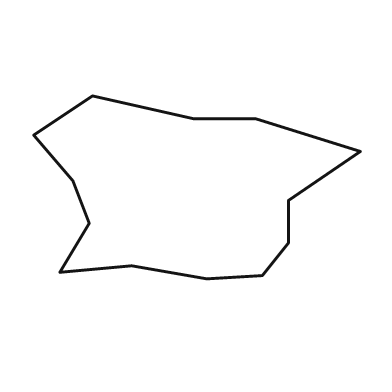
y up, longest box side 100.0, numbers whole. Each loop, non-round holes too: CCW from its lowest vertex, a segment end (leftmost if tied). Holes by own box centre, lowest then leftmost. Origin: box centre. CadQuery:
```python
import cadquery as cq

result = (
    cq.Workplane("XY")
    .moveTo(3.0, -28.0)
    .lineTo(20.0, -27.0)
    .lineTo(28.0, -17.0)
    .lineTo(28.0, -4.0)
    .lineTo(50.0, 11.0)
    .lineTo(18.0, 21.0)
    .lineTo(-1.0, 21.0)
    .lineTo(-32.0, 28.0)
    .lineTo(-50.0, 16.0)
    .lineTo(-38.0, 2.0)
    .lineTo(-33.0, -11.0)
    .lineTo(-42.0, -26.0)
    .lineTo(-20.0, -24.0)
    .close()
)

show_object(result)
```